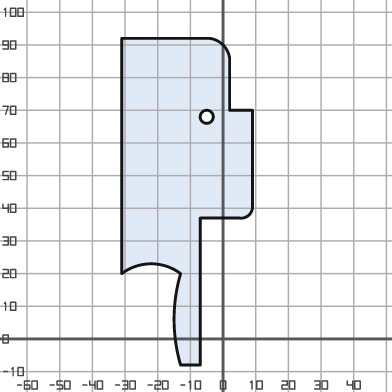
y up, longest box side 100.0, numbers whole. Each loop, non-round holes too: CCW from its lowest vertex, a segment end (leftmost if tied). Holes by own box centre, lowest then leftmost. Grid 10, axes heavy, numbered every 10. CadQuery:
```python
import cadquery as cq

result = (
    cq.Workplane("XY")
    .moveTo(-13.0, -8.0)
    .lineTo(-7.0, -8.0)
    .lineTo(-7.0, 37.0)
    .lineTo(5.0, 37.0)
    .threePointArc((8.0, 38.0), (9.0, 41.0))
    .lineTo(9.0, 70.0)
    .lineTo(2.0, 70.0)
    .lineTo(2.0, 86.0)
    .threePointArc((0.0, 90.0), (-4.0, 92.0))
    .lineTo(-31.0, 92.0)
    .lineTo(-31.0, 20.0)
    .threePointArc((-22.0, 23.0), (-13.0, 20.0))
    .threePointArc((-15.0, 6.0), (-13.0, -8.0))
    .close()
    .moveTo(-5.0, 68.0)
    .circle(2.0)
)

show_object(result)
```